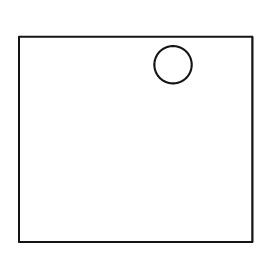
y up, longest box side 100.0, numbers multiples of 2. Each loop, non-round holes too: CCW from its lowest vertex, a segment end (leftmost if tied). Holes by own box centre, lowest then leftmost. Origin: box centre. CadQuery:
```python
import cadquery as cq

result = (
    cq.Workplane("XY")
    .moveTo(-50.0, -44.0)
    .lineTo(50.0, -44.0)
    .lineTo(50.0, 44.0)
    .lineTo(-50.0, 44.0)
    .close()
    .moveTo(16.0, 32.0)
    .circle(8.0)
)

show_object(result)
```